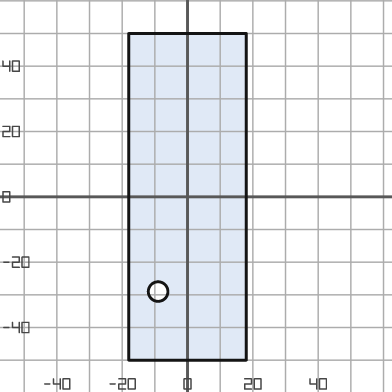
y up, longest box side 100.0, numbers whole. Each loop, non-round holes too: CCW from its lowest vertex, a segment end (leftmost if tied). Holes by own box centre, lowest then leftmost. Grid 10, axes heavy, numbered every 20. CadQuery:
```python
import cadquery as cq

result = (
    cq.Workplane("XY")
    .moveTo(-18.0, -50.0)
    .lineTo(18.0, -50.0)
    .lineTo(18.0, 50.0)
    .lineTo(-18.0, 50.0)
    .close()
    .moveTo(-9.0, -29.0)
    .circle(3.0)
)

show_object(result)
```